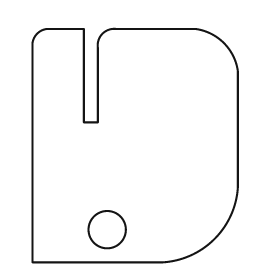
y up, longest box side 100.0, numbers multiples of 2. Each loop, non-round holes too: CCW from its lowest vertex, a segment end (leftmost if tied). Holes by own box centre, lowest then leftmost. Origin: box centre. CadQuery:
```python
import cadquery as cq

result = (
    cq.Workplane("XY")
    .moveTo(-44.0, -50.0)
    .lineTo(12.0, -50.0)
    .threePointArc((34.0, -40.0), (44.0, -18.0))
    .lineTo(44.0, 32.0)
    .threePointArc((38.0, 44.0), (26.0, 50.0))
    .lineTo(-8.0, 50.0)
    .threePointArc((-14.0, 48.0), (-16.0, 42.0))
    .lineTo(-16.0, 10.0)
    .lineTo(-22.0, 10.0)
    .lineTo(-22.0, 50.0)
    .lineTo(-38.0, 50.0)
    .threePointArc((-42.0, 48.0), (-44.0, 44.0))
    .close()
    .moveTo(-12.0, -36.0)
    .circle(8.0)
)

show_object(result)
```